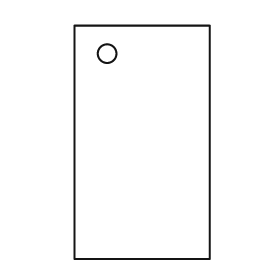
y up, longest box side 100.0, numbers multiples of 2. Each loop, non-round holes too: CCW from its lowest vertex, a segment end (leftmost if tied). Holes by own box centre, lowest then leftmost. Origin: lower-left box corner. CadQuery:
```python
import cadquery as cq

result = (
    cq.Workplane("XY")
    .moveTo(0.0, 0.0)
    .lineTo(58.0, 0.0)
    .lineTo(58.0, 100.0)
    .lineTo(0.0, 100.0)
    .close()
    .moveTo(14.0, 88.0)
    .circle(4.0)
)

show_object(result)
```